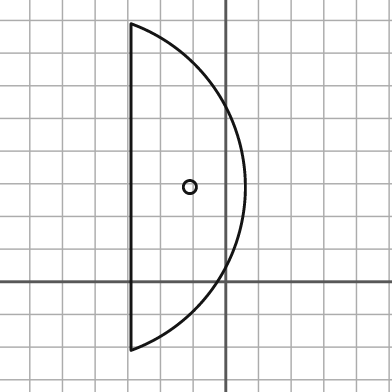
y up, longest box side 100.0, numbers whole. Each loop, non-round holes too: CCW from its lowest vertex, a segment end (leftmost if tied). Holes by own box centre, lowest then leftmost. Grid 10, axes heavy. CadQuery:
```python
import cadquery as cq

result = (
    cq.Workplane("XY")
    .moveTo(-29.0, -21.0)
    .threePointArc((6.0, 29.0), (-29.0, 79.0))
    .close()
    .moveTo(-11.0, 29.0)
    .circle(2.0)
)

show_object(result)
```